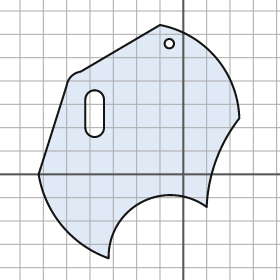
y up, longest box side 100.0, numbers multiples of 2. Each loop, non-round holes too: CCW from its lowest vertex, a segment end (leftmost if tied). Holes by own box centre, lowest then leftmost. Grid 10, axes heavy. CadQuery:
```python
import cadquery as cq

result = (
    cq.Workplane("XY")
    .moveTo(-32.0, -36.0)
    .threePointArc((-18.0, -12.0), (10.0, -14.0))
    .threePointArc((14.0, 6.0), (24.0, 24.0))
    .threePointArc((14.0, 50.0), (-10.0, 64.0))
    .lineTo(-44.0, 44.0)
    .threePointArc((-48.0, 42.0), (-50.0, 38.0))
    .lineTo(-62.0, 0.0)
    .threePointArc((-52.0, -22.0), (-32.0, -36.0))
    .close()
    .moveTo(-42.0, 20.0)
    .threePointArc((-38.0, 16.0), (-34.0, 20.0))
    .lineTo(-34.0, 32.0)
    .threePointArc((-38.0, 36.0), (-42.0, 32.0))
    .close()
    .moveTo(-6.0, 56.0)
    .circle(2.0)
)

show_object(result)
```